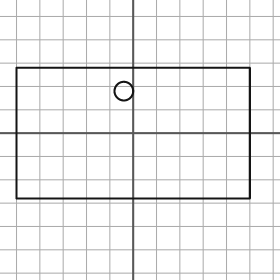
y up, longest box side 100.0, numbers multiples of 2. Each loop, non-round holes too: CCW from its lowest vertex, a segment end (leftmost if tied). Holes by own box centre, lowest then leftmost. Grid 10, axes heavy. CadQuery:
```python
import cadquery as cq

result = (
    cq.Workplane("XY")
    .moveTo(-50.0, -28.0)
    .lineTo(50.0, -28.0)
    .lineTo(50.0, 28.0)
    .lineTo(-50.0, 28.0)
    .close()
    .moveTo(-4.0, 18.0)
    .circle(4.0)
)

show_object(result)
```